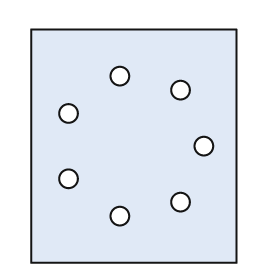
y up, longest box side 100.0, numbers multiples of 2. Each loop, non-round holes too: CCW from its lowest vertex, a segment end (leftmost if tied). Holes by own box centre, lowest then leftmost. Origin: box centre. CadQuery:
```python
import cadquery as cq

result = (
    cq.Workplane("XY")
    .moveTo(-44.0, -50.0)
    .lineTo(44.0, -50.0)
    .lineTo(44.0, 50.0)
    .lineTo(-44.0, 50.0)
    .close()
    .moveTo(-6.0, -30.0)
    .circle(4.0)
    .moveTo(20.0, -24.0)
    .circle(4.0)
    .moveTo(-28.0, -14.0)
    .circle(4.0)
    .moveTo(30.0, 0.0)
    .circle(4.0)
    .moveTo(-28.0, 14.0)
    .circle(4.0)
    .moveTo(20.0, 24.0)
    .circle(4.0)
    .moveTo(-6.0, 30.0)
    .circle(4.0)
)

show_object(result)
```